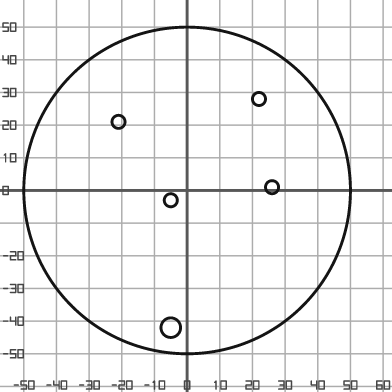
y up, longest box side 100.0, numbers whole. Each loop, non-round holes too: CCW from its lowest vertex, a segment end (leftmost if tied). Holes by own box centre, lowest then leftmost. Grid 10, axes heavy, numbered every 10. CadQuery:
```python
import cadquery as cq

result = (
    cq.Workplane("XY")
    .moveTo(0.0, 0.0)
    .circle(50.0)
    .moveTo(-5.0, -42.0)
    .circle(3.0)
    .moveTo(-5.0, -3.0)
    .circle(2.0)
    .moveTo(26.0, 1.0)
    .circle(2.0)
    .moveTo(-21.0, 21.0)
    .circle(2.0)
    .moveTo(22.0, 28.0)
    .circle(2.0)
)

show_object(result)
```